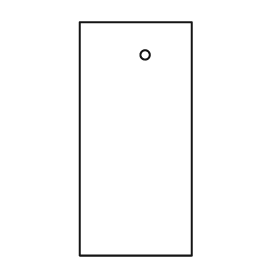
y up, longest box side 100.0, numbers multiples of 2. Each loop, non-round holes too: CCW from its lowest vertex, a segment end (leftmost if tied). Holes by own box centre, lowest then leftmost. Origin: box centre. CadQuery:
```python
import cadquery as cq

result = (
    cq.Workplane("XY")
    .moveTo(-24.0, -50.0)
    .lineTo(24.0, -50.0)
    .lineTo(24.0, 50.0)
    .lineTo(-24.0, 50.0)
    .close()
    .moveTo(4.0, 36.0)
    .circle(2.0)
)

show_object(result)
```